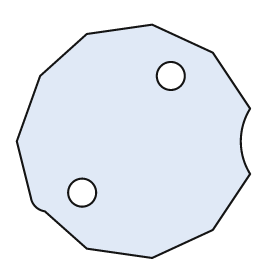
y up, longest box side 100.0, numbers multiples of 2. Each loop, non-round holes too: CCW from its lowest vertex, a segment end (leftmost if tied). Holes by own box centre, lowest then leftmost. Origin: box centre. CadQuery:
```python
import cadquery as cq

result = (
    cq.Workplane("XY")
    .moveTo(8.0, -50.0)
    .lineTo(34.0, -38.0)
    .lineTo(50.0, -14.0)
    .threePointArc((46.0, 0.0), (50.0, 14.0))
    .lineTo(34.0, 38.0)
    .lineTo(8.0, 50.0)
    .lineTo(-20.0, 46.0)
    .lineTo(-40.0, 28.0)
    .lineTo(-50.0, 0.0)
    .lineTo(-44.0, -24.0)
    .threePointArc((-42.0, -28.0), (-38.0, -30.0))
    .lineTo(-20.0, -46.0)
    .close()
    .moveTo(-22.0, -22.0)
    .circle(6.0)
    .moveTo(16.0, 28.0)
    .circle(6.0)
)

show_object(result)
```